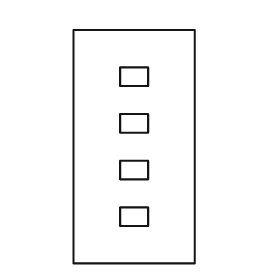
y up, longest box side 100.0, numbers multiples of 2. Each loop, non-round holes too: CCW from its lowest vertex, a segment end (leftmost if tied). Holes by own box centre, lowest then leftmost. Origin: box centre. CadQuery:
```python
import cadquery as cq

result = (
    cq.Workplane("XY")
    .moveTo(-26.0, -50.0)
    .lineTo(26.0, -50.0)
    .lineTo(26.0, 50.0)
    .lineTo(-26.0, 50.0)
    .close()
    .moveTo(-6.0, -34.0)
    .lineTo(6.0, -34.0)
    .lineTo(6.0, -26.0)
    .lineTo(-6.0, -26.0)
    .close()
    .moveTo(-6.0, -14.0)
    .lineTo(6.0, -14.0)
    .lineTo(6.0, -6.0)
    .lineTo(-6.0, -6.0)
    .close()
    .moveTo(-6.0, 6.0)
    .lineTo(6.0, 6.0)
    .lineTo(6.0, 14.0)
    .lineTo(-6.0, 14.0)
    .close()
    .moveTo(-6.0, 26.0)
    .lineTo(6.0, 26.0)
    .lineTo(6.0, 34.0)
    .lineTo(-6.0, 34.0)
    .close()
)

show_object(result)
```